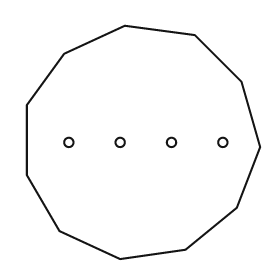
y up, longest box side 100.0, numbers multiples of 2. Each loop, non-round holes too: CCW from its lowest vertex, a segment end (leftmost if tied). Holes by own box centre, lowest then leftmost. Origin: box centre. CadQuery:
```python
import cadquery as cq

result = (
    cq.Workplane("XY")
    .moveTo(-10.0, -50.0)
    .lineTo(18.0, -46.0)
    .lineTo(40.0, -28.0)
    .lineTo(50.0, -2.0)
    .lineTo(42.0, 26.0)
    .lineTo(22.0, 46.0)
    .lineTo(-8.0, 50.0)
    .lineTo(-34.0, 38.0)
    .lineTo(-50.0, 16.0)
    .lineTo(-50.0, -14.0)
    .lineTo(-36.0, -38.0)
    .close()
    .moveTo(-32.0, 0.0)
    .circle(2.0)
    .moveTo(-10.0, 0.0)
    .circle(2.0)
    .moveTo(12.0, 0.0)
    .circle(2.0)
    .moveTo(34.0, 0.0)
    .circle(2.0)
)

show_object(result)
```